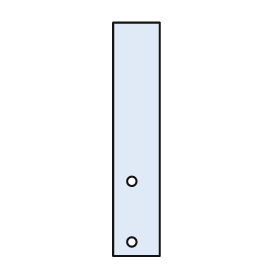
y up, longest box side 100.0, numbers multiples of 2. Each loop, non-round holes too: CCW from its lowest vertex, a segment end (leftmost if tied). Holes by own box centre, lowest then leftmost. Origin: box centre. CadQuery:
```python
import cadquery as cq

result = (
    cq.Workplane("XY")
    .moveTo(-10.0, -50.0)
    .lineTo(10.0, -50.0)
    .lineTo(10.0, 50.0)
    .lineTo(-10.0, 50.0)
    .close()
    .moveTo(-2.0, -44.0)
    .circle(2.0)
    .moveTo(-2.0, -18.0)
    .circle(2.0)
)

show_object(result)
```